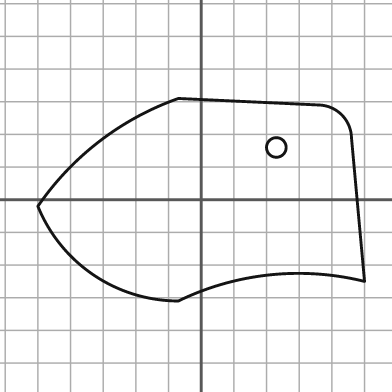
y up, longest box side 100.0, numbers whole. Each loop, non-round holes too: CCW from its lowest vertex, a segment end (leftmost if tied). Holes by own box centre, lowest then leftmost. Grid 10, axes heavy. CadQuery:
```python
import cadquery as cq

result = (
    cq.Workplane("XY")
    .moveTo(-7.0, -31.0)
    .threePointArc((21.0, -23.0), (50.0, -25.0))
    .lineTo(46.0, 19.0)
    .threePointArc((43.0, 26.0), (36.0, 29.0))
    .lineTo(-7.0, 31.0)
    .threePointArc((-31.0, 18.0), (-50.0, -2.0))
    .threePointArc((-33.0, -23.0), (-7.0, -31.0))
    .close()
    .moveTo(23.0, 16.0)
    .circle(3.0)
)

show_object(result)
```